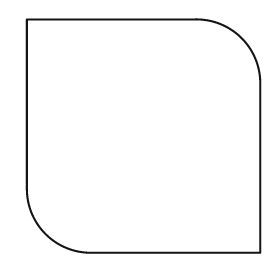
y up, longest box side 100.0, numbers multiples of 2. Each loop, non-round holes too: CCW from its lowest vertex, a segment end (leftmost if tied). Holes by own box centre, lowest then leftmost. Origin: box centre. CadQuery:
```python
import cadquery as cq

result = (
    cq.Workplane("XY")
    .moveTo(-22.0, -50.0)
    .lineTo(50.0, -50.0)
    .lineTo(50.0, 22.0)
    .threePointArc((42.0, 42.0), (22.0, 50.0))
    .lineTo(-50.0, 50.0)
    .lineTo(-50.0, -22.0)
    .threePointArc((-42.0, -42.0), (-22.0, -50.0))
    .close()
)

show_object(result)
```